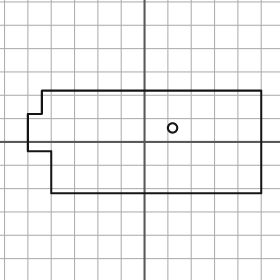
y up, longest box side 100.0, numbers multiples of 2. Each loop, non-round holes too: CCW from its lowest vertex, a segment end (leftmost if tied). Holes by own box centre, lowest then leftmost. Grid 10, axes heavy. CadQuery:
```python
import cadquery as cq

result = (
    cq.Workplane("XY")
    .moveTo(-40.0, -22.0)
    .lineTo(50.0, -22.0)
    .lineTo(50.0, 22.0)
    .lineTo(-44.0, 22.0)
    .lineTo(-44.0, 12.0)
    .lineTo(-50.0, 12.0)
    .lineTo(-50.0, -4.0)
    .lineTo(-40.0, -4.0)
    .close()
    .moveTo(12.0, 6.0)
    .circle(2.0)
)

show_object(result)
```